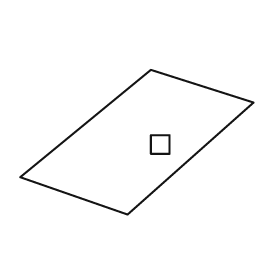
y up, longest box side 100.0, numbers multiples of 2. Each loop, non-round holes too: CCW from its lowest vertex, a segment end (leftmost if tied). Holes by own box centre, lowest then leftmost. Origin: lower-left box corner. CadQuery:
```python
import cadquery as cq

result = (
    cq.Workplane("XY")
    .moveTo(46.0, 0.0)
    .lineTo(100.0, 48.0)
    .lineTo(56.0, 62.0)
    .lineTo(0.0, 16.0)
    .close()
    .moveTo(56.0, 26.0)
    .lineTo(64.0, 26.0)
    .lineTo(64.0, 34.0)
    .lineTo(56.0, 34.0)
    .close()
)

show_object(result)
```